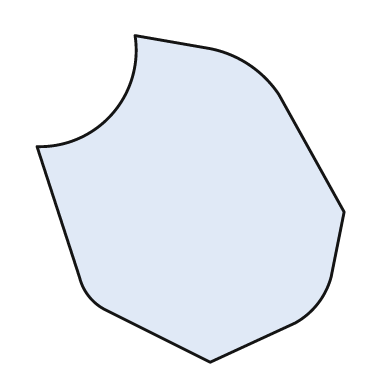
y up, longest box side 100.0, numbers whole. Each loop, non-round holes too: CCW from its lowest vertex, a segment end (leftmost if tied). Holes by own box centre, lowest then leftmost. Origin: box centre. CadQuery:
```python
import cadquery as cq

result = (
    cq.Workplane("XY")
    .moveTo(6.0, -50.0)
    .lineTo(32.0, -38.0)
    .threePointArc((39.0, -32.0), (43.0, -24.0))
    .lineTo(47.0, -4.0)
    .lineTo(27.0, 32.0)
    .threePointArc((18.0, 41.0), (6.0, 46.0))
    .lineTo(-17.0, 50.0)
    .threePointArc((-24.0, 26.0), (-47.0, 16.0))
    .lineTo(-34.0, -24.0)
    .threePointArc((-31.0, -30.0), (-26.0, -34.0))
    .close()
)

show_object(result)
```